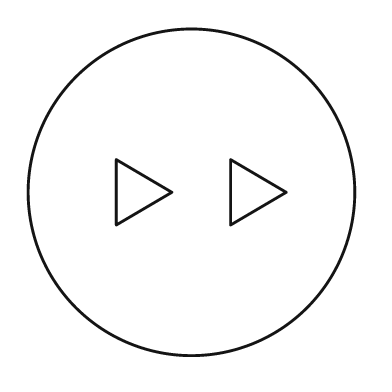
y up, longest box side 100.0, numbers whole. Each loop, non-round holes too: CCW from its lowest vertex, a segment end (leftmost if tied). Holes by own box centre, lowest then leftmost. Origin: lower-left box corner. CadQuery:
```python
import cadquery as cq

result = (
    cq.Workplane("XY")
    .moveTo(50.0, 50.0)
    .circle(50.0)
    .moveTo(27.0, 40.0)
    .lineTo(44.0, 50.0)
    .lineTo(27.0, 60.0)
    .close()
    .moveTo(62.0, 40.0)
    .lineTo(79.0, 50.0)
    .lineTo(62.0, 60.0)
    .close()
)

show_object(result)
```